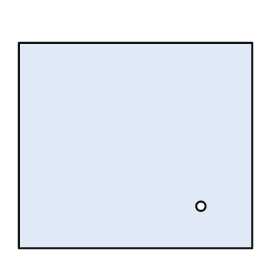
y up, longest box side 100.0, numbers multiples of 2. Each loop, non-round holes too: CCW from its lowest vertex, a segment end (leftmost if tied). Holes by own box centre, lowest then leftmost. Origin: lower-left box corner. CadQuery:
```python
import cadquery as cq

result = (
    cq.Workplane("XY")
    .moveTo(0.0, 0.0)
    .lineTo(100.0, 0.0)
    .lineTo(100.0, 88.0)
    .lineTo(0.0, 88.0)
    .close()
    .moveTo(78.0, 18.0)
    .circle(2.0)
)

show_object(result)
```